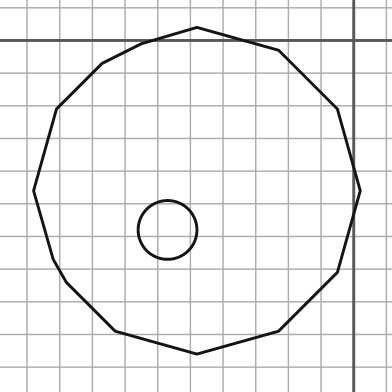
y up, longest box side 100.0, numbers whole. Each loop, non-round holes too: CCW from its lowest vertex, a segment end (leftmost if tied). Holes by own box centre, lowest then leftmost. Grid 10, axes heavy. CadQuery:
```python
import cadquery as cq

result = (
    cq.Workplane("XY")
    .moveTo(-48.0, -96.0)
    .lineTo(-23.0, -89.0)
    .lineTo(-5.0, -71.0)
    .lineTo(2.0, -46.0)
    .lineTo(-5.0, -21.0)
    .lineTo(-23.0, -3.0)
    .lineTo(-48.0, 4.0)
    .lineTo(-65.0, -1.0)
    .lineTo(-77.0, -7.0)
    .lineTo(-91.0, -21.0)
    .lineTo(-98.0, -46.0)
    .lineTo(-92.0, -67.0)
    .lineTo(-88.0, -74.0)
    .lineTo(-73.0, -89.0)
    .close()
    .moveTo(-57.0, -58.0)
    .circle(9.0)
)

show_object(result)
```